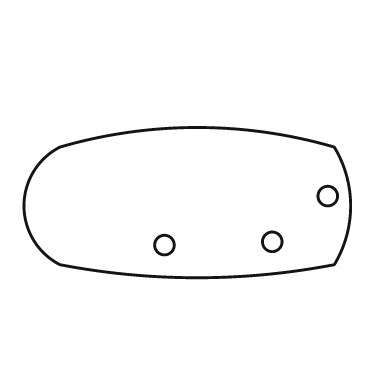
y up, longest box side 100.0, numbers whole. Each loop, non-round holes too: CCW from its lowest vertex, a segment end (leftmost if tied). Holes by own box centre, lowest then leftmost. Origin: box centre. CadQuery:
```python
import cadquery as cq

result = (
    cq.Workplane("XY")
    .moveTo(-39.0, -19.0)
    .threePointArc((3.0, -23.0), (45.0, -19.0))
    .threePointArc((50.0, -1.0), (45.0, 17.0))
    .threePointArc((3.0, 23.0), (-39.0, 17.0))
    .threePointArc((-50.0, -1.0), (-39.0, -19.0))
    .close()
    .moveTo(-7.0, -13.0)
    .circle(3.0)
    .moveTo(26.0, -12.0)
    .circle(3.0)
    .moveTo(43.0, 2.0)
    .circle(3.0)
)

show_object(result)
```